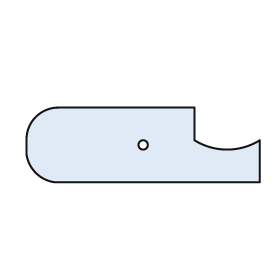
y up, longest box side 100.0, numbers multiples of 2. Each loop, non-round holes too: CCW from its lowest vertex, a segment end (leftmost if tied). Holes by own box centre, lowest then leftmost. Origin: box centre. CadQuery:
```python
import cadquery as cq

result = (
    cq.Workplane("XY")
    .moveTo(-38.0, -16.0)
    .lineTo(50.0, -16.0)
    .lineTo(50.0, 2.0)
    .threePointArc((36.0, -2.0), (22.0, 2.0))
    .lineTo(22.0, 16.0)
    .lineTo(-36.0, 16.0)
    .threePointArc((-46.0, 12.0), (-50.0, 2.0))
    .lineTo(-50.0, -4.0)
    .threePointArc((-46.0, -12.0), (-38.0, -16.0))
    .close()
    .moveTo(0.0, 0.0)
    .circle(2.0)
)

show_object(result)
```